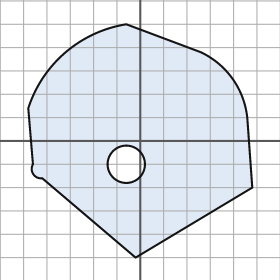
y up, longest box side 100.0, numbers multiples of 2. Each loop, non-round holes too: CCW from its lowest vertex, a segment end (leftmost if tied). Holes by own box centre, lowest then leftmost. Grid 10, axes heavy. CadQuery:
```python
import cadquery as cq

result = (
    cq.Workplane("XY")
    .moveTo(-2.0, -50.0)
    .lineTo(48.0, -20.0)
    .lineTo(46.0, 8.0)
    .threePointArc((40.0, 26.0), (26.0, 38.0))
    .lineTo(-6.0, 50.0)
    .threePointArc((-32.0, 38.0), (-48.0, 14.0))
    .lineTo(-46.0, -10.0)
    .threePointArc((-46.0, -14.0), (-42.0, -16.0))
    .close()
    .moveTo(-6.0, -10.0)
    .circle(8.0)
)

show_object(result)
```